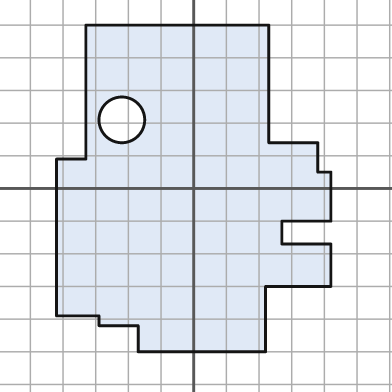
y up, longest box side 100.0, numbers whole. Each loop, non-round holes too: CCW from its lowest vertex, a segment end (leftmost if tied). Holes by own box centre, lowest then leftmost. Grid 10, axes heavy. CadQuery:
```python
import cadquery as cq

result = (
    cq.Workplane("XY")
    .moveTo(-17.0, -50.0)
    .lineTo(22.0, -50.0)
    .lineTo(22.0, -30.0)
    .lineTo(42.0, -30.0)
    .lineTo(42.0, -17.0)
    .lineTo(27.0, -17.0)
    .lineTo(27.0, -10.0)
    .lineTo(42.0, -10.0)
    .lineTo(42.0, 5.0)
    .lineTo(38.0, 5.0)
    .lineTo(38.0, 14.0)
    .lineTo(23.0, 14.0)
    .lineTo(23.0, 50.0)
    .lineTo(-33.0, 50.0)
    .lineTo(-33.0, 9.0)
    .lineTo(-42.0, 9.0)
    .lineTo(-42.0, -39.0)
    .lineTo(-29.0, -39.0)
    .lineTo(-29.0, -42.0)
    .lineTo(-17.0, -42.0)
    .close()
    .moveTo(-22.0, 21.0)
    .circle(7.0)
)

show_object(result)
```